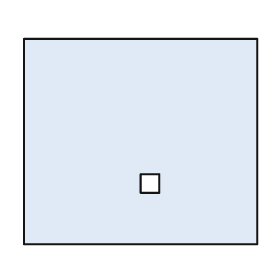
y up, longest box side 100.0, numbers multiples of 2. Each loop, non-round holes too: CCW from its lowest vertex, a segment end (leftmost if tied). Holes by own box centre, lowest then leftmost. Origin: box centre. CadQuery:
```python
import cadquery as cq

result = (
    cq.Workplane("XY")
    .moveTo(-50.0, -44.0)
    .lineTo(50.0, -44.0)
    .lineTo(50.0, 44.0)
    .lineTo(-50.0, 44.0)
    .close()
    .moveTo(0.0, -22.0)
    .lineTo(8.0, -22.0)
    .lineTo(8.0, -14.0)
    .lineTo(0.0, -14.0)
    .close()
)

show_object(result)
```